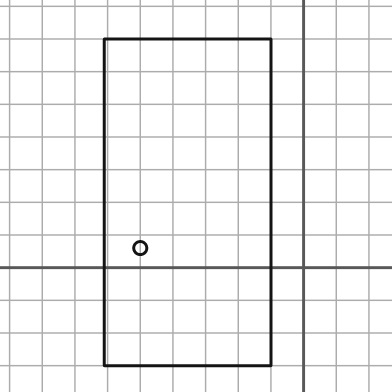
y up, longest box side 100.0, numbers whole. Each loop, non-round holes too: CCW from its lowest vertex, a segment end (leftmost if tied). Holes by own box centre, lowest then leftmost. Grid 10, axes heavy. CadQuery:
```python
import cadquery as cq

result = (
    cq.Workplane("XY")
    .moveTo(-61.0, -30.0)
    .lineTo(-10.0, -30.0)
    .lineTo(-10.0, 70.0)
    .lineTo(-61.0, 70.0)
    .close()
    .moveTo(-50.0, 6.0)
    .circle(2.0)
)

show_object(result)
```